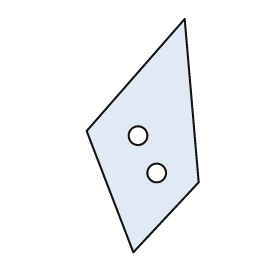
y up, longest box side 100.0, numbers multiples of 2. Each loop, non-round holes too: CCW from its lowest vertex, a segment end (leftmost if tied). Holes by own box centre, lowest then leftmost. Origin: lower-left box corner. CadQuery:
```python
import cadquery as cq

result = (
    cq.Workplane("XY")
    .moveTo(20.0, 0.0)
    .lineTo(48.0, 30.0)
    .lineTo(42.0, 100.0)
    .lineTo(0.0, 52.0)
    .close()
    .moveTo(30.0, 34.0)
    .circle(4.0)
    .moveTo(22.0, 50.0)
    .circle(4.0)
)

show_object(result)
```